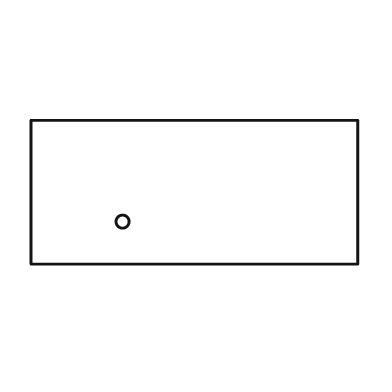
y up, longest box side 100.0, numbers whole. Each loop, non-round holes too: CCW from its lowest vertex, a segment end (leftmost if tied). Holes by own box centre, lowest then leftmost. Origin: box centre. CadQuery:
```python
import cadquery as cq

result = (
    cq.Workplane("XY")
    .moveTo(-50.0, -22.0)
    .lineTo(50.0, -22.0)
    .lineTo(50.0, 22.0)
    .lineTo(-50.0, 22.0)
    .close()
    .moveTo(-22.0, -9.0)
    .circle(2.0)
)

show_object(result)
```